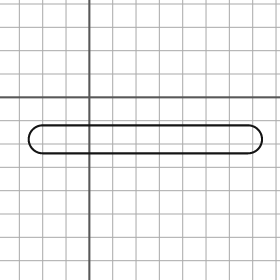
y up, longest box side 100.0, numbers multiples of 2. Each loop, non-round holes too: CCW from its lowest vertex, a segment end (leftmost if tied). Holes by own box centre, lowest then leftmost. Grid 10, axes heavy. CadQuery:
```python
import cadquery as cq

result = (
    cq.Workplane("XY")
    .moveTo(-20.0, -24.0)
    .lineTo(68.0, -24.0)
    .threePointArc((74.0, -18.0), (68.0, -12.0))
    .lineTo(-20.0, -12.0)
    .threePointArc((-26.0, -18.0), (-20.0, -24.0))
    .close()
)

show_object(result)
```